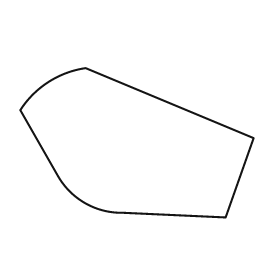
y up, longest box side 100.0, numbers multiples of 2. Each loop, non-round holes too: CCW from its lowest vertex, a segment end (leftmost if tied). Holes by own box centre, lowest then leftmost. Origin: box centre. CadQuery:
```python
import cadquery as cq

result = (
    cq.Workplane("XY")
    .moveTo(38.0, -32.0)
    .lineTo(50.0, 2.0)
    .lineTo(-22.0, 32.0)
    .threePointArc((-38.0, 26.0), (-50.0, 14.0))
    .lineTo(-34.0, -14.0)
    .threePointArc((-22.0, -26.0), (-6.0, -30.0))
    .close()
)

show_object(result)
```